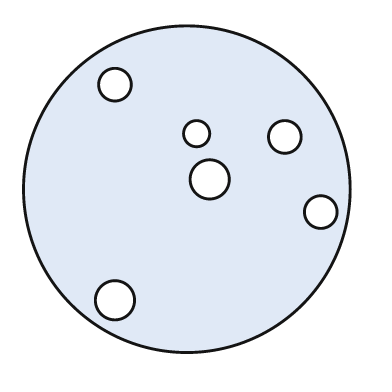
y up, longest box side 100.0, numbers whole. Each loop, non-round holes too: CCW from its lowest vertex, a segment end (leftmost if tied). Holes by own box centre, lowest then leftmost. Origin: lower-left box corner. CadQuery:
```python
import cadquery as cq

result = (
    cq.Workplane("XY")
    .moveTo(50.0, 50.0)
    .circle(50.0)
    .moveTo(28.0, 16.0)
    .circle(6.0)
    .moveTo(91.0, 43.0)
    .circle(5.0)
    .moveTo(57.0, 53.0)
    .circle(6.0)
    .moveTo(80.0, 66.0)
    .circle(5.0)
    .moveTo(53.0, 67.0)
    .circle(4.0)
    .moveTo(28.0, 82.0)
    .circle(5.0)
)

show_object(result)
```